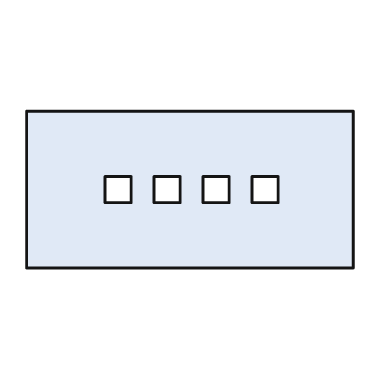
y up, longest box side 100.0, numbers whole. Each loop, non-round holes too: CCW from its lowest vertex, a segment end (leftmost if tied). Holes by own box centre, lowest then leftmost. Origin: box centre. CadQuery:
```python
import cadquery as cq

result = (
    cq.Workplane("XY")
    .moveTo(-50.0, -24.0)
    .lineTo(50.0, -24.0)
    .lineTo(50.0, 24.0)
    .lineTo(-50.0, 24.0)
    .close()
    .moveTo(-26.0, -4.0)
    .lineTo(-18.0, -4.0)
    .lineTo(-18.0, 4.0)
    .lineTo(-26.0, 4.0)
    .close()
    .moveTo(-11.0, -4.0)
    .lineTo(-3.0, -4.0)
    .lineTo(-3.0, 4.0)
    .lineTo(-11.0, 4.0)
    .close()
    .moveTo(4.0, -4.0)
    .lineTo(12.0, -4.0)
    .lineTo(12.0, 4.0)
    .lineTo(4.0, 4.0)
    .close()
    .moveTo(19.0, -4.0)
    .lineTo(27.0, -4.0)
    .lineTo(27.0, 4.0)
    .lineTo(19.0, 4.0)
    .close()
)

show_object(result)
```